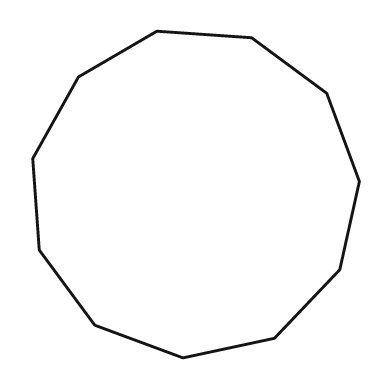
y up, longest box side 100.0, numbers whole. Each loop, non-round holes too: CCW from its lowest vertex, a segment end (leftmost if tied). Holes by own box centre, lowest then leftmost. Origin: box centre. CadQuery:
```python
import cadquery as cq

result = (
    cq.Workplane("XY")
    .moveTo(-4.0, -50.0)
    .lineTo(24.0, -44.0)
    .lineTo(44.0, -23.0)
    .lineTo(50.0, 4.0)
    .lineTo(40.0, 31.0)
    .lineTo(17.0, 48.0)
    .lineTo(-12.0, 50.0)
    .lineTo(-36.0, 36.0)
    .lineTo(-50.0, 11.0)
    .lineTo(-48.0, -17.0)
    .lineTo(-31.0, -40.0)
    .close()
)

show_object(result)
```